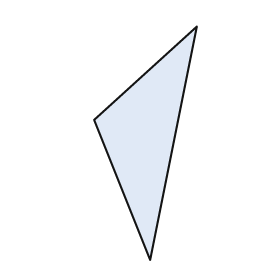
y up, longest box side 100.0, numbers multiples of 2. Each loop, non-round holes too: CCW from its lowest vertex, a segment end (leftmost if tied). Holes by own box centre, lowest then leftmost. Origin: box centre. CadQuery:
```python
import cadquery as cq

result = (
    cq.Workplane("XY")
    .moveTo(2.0, -50.0)
    .lineTo(22.0, 50.0)
    .lineTo(-22.0, 10.0)
    .close()
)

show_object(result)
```